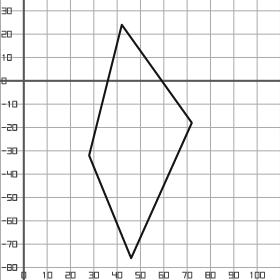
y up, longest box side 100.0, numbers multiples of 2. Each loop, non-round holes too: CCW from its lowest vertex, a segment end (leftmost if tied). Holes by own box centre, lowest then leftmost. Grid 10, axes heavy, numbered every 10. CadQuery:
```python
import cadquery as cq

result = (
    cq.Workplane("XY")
    .moveTo(46.0, -76.0)
    .lineTo(72.0, -18.0)
    .lineTo(42.0, 24.0)
    .lineTo(28.0, -32.0)
    .close()
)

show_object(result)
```